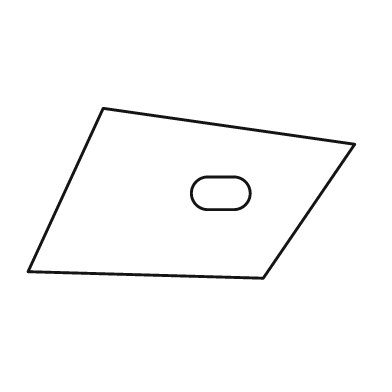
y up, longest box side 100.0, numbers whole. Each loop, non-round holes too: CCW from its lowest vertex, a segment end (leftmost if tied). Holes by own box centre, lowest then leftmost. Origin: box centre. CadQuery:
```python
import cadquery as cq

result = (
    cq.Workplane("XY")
    .moveTo(22.0, -26.0)
    .lineTo(50.0, 15.0)
    .lineTo(-27.0, 26.0)
    .lineTo(-50.0, -24.0)
    .close()
    .moveTo(5.0, -5.0)
    .lineTo(13.0, -5.0)
    .threePointArc((18.0, 0.0), (13.0, 5.0))
    .lineTo(5.0, 5.0)
    .threePointArc((0.0, 0.0), (5.0, -5.0))
    .close()
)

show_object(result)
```